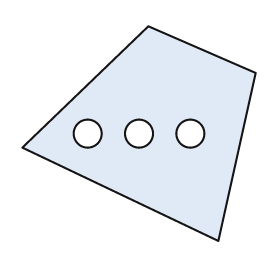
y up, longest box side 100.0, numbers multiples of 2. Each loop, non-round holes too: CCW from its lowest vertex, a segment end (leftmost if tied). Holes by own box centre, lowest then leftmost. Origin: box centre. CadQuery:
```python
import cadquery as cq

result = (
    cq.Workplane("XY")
    .moveTo(34.0, -46.0)
    .lineTo(50.0, 26.0)
    .lineTo(4.0, 46.0)
    .lineTo(-50.0, -6.0)
    .close()
    .moveTo(-22.0, 0.0)
    .circle(6.0)
    .moveTo(0.0, 0.0)
    .circle(6.0)
    .moveTo(22.0, 0.0)
    .circle(6.0)
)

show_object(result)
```